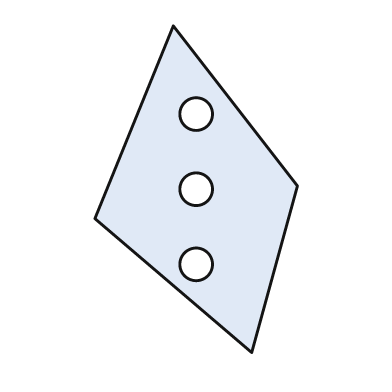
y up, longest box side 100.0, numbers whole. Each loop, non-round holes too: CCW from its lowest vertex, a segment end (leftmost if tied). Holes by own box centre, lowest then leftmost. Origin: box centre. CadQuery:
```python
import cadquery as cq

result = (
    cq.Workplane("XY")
    .moveTo(17.0, -50.0)
    .lineTo(31.0, 1.0)
    .lineTo(-7.0, 50.0)
    .lineTo(-31.0, -9.0)
    .close()
    .moveTo(0.0, -23.0)
    .circle(5.0)
    .moveTo(0.0, 0.0)
    .circle(5.0)
    .moveTo(0.0, 23.0)
    .circle(5.0)
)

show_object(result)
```